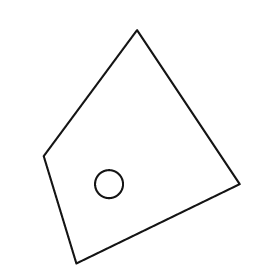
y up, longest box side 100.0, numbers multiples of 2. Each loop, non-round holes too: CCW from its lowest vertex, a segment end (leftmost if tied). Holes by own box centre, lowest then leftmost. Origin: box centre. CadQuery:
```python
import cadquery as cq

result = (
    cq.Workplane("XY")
    .moveTo(-28.0, -50.0)
    .lineTo(42.0, -16.0)
    .lineTo(-2.0, 50.0)
    .lineTo(-42.0, -4.0)
    .close()
    .moveTo(-14.0, -16.0)
    .circle(6.0)
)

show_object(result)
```